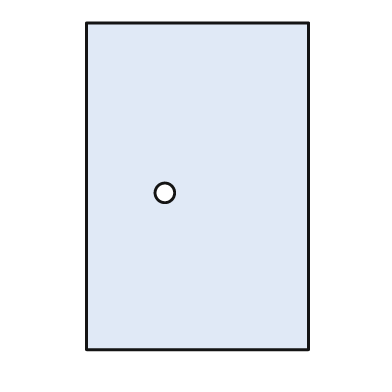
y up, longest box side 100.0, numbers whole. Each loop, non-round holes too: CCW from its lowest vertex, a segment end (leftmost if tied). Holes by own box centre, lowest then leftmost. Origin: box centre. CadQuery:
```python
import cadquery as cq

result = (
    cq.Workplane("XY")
    .moveTo(-34.0, -50.0)
    .lineTo(34.0, -50.0)
    .lineTo(34.0, 50.0)
    .lineTo(-34.0, 50.0)
    .close()
    .moveTo(-10.0, -2.0)
    .circle(3.0)
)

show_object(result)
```